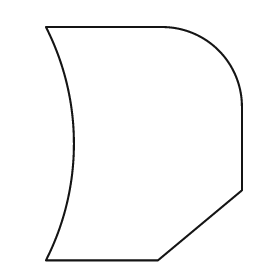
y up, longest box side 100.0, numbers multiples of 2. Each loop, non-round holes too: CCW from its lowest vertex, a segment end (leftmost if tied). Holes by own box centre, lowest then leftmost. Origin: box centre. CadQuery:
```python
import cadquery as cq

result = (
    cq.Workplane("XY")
    .moveTo(-42.0, -50.0)
    .lineTo(6.0, -50.0)
    .lineTo(42.0, -20.0)
    .lineTo(42.0, 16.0)
    .threePointArc((32.0, 40.0), (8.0, 50.0))
    .lineTo(-42.0, 50.0)
    .threePointArc((-30.0, 0.0), (-42.0, -50.0))
    .close()
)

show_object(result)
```